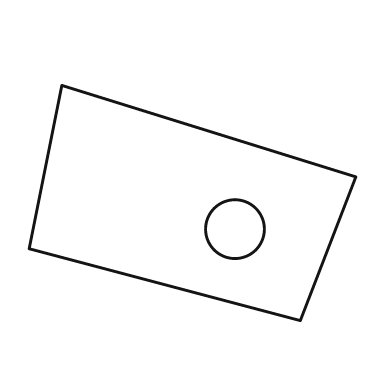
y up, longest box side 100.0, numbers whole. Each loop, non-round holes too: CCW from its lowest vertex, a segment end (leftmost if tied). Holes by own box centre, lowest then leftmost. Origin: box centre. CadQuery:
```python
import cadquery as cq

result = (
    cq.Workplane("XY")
    .moveTo(33.0, -36.0)
    .lineTo(50.0, 8.0)
    .lineTo(-40.0, 36.0)
    .lineTo(-50.0, -14.0)
    .close()
    .moveTo(13.0, -8.0)
    .circle(9.0)
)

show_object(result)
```